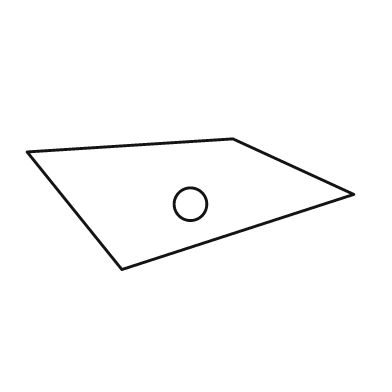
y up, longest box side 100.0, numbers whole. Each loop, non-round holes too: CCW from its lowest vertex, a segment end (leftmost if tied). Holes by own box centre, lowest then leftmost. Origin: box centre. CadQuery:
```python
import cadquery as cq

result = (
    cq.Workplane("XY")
    .moveTo(-21.0, -20.0)
    .lineTo(50.0, 3.0)
    .lineTo(13.0, 20.0)
    .lineTo(-50.0, 16.0)
    .close()
    .moveTo(0.0, 0.0)
    .circle(5.0)
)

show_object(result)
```